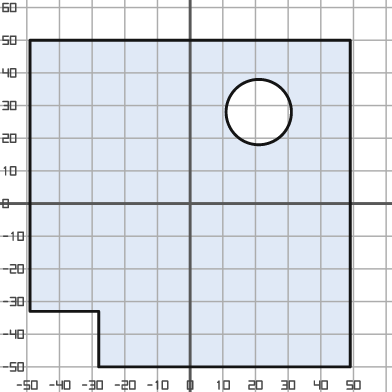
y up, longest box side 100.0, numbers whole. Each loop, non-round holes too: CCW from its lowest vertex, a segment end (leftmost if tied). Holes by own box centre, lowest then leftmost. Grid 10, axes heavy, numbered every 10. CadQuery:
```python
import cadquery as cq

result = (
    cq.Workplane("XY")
    .moveTo(-28.0, -50.0)
    .lineTo(49.0, -50.0)
    .lineTo(49.0, 50.0)
    .lineTo(-49.0, 50.0)
    .lineTo(-49.0, -33.0)
    .lineTo(-28.0, -33.0)
    .close()
    .moveTo(21.0, 28.0)
    .circle(10.0)
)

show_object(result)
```